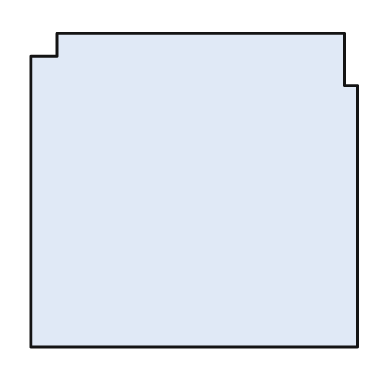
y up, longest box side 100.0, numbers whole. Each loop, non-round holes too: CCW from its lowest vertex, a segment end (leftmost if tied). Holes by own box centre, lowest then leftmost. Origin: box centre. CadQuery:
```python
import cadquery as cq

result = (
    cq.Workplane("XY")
    .moveTo(-50.0, -48.0)
    .lineTo(50.0, -48.0)
    .lineTo(50.0, 32.0)
    .lineTo(46.0, 32.0)
    .lineTo(46.0, 48.0)
    .lineTo(-42.0, 48.0)
    .lineTo(-42.0, 41.0)
    .lineTo(-50.0, 41.0)
    .close()
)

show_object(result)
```